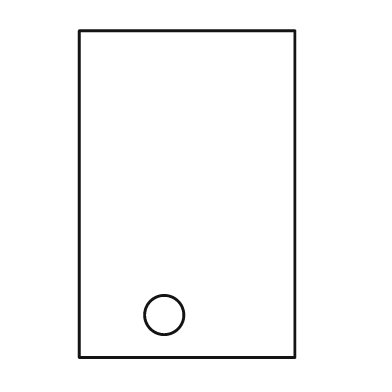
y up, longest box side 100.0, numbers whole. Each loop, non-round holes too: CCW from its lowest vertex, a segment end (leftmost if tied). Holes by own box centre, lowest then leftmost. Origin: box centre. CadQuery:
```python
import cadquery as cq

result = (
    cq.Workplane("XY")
    .moveTo(-33.0, -50.0)
    .lineTo(33.0, -50.0)
    .lineTo(33.0, 50.0)
    .lineTo(-33.0, 50.0)
    .close()
    .moveTo(-7.0, -37.0)
    .circle(6.0)
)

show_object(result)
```